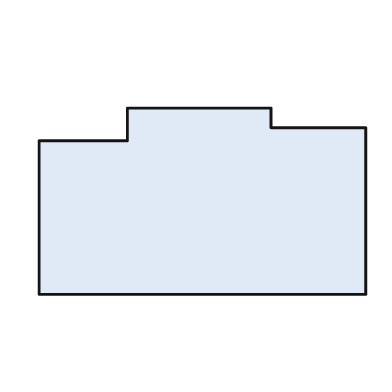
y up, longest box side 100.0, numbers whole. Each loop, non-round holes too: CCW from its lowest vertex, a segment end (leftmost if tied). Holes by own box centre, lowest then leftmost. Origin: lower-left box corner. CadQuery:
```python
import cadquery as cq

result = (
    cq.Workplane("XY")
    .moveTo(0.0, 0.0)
    .lineTo(100.0, 0.0)
    .lineTo(100.0, 51.0)
    .lineTo(71.0, 51.0)
    .lineTo(71.0, 57.0)
    .lineTo(27.0, 57.0)
    .lineTo(27.0, 47.0)
    .lineTo(0.0, 47.0)
    .close()
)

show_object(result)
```